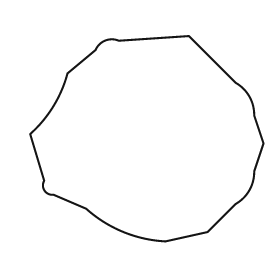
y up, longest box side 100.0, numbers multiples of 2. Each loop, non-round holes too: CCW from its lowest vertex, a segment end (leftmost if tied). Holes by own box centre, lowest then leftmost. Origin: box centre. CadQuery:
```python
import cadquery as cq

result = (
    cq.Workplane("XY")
    .moveTo(8.0, -44.0)
    .lineTo(26.0, -40.0)
    .lineTo(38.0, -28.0)
    .threePointArc((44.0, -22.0), (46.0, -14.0))
    .lineTo(50.0, -2.0)
    .lineTo(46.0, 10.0)
    .threePointArc((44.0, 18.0), (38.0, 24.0))
    .lineTo(18.0, 44.0)
    .lineTo(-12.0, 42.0)
    .threePointArc((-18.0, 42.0), (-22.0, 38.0))
    .lineTo(-34.0, 28.0)
    .threePointArc((-40.0, 14.0), (-50.0, 2.0))
    .lineTo(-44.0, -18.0)
    .threePointArc((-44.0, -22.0), (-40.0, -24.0))
    .lineTo(-26.0, -30.0)
    .threePointArc((-10.0, -40.0), (8.0, -44.0))
    .close()
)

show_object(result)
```